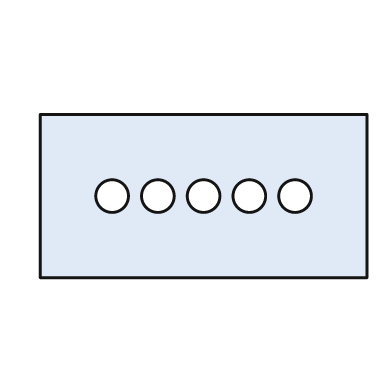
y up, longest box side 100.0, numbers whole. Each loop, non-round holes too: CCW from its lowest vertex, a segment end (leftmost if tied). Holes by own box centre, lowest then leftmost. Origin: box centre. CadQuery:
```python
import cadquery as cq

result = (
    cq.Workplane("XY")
    .moveTo(-50.0, -25.0)
    .lineTo(50.0, -25.0)
    .lineTo(50.0, 25.0)
    .lineTo(-50.0, 25.0)
    .close()
    .moveTo(-28.0, 0.0)
    .circle(5.0)
    .moveTo(-14.0, 0.0)
    .circle(5.0)
    .moveTo(0.0, 0.0)
    .circle(5.0)
    .moveTo(14.0, 0.0)
    .circle(5.0)
    .moveTo(28.0, 0.0)
    .circle(5.0)
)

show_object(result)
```